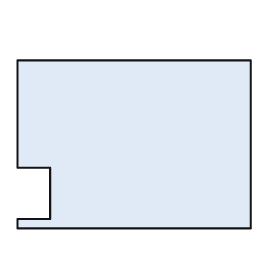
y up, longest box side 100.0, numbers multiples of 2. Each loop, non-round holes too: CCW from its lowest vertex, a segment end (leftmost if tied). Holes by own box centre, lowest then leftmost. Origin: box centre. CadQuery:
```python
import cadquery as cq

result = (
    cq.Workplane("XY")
    .moveTo(-50.0, -36.0)
    .lineTo(50.0, -36.0)
    .lineTo(50.0, 36.0)
    .lineTo(-50.0, 36.0)
    .lineTo(-50.0, -10.0)
    .lineTo(-36.0, -10.0)
    .lineTo(-36.0, -32.0)
    .lineTo(-50.0, -32.0)
    .close()
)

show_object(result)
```